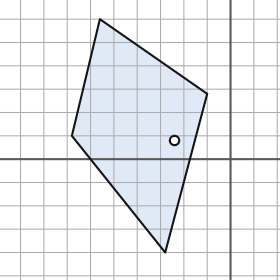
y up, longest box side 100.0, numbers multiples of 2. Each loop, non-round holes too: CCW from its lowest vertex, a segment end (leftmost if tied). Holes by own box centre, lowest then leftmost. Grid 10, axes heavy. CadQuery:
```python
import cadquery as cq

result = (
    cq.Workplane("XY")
    .moveTo(-28.0, -40.0)
    .lineTo(-10.0, 28.0)
    .lineTo(-56.0, 60.0)
    .lineTo(-68.0, 10.0)
    .close()
    .moveTo(-24.0, 8.0)
    .circle(2.0)
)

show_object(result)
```